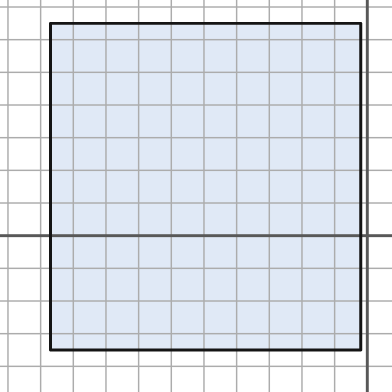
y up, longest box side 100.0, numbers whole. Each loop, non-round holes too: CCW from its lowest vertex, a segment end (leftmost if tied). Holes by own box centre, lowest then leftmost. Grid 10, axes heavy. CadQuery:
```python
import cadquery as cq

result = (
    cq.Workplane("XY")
    .moveTo(-97.0, -35.0)
    .lineTo(-2.0, -35.0)
    .lineTo(-2.0, 65.0)
    .lineTo(-97.0, 65.0)
    .close()
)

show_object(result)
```